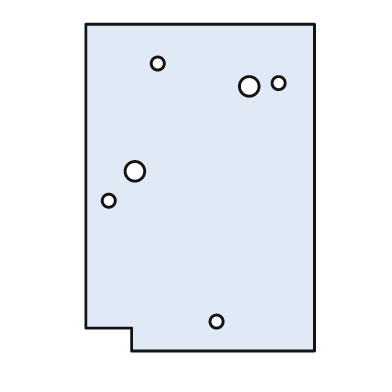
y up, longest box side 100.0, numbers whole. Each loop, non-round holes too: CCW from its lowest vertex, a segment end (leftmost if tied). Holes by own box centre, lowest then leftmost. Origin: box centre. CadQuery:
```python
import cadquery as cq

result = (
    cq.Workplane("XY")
    .moveTo(-21.0, -50.0)
    .lineTo(35.0, -50.0)
    .lineTo(35.0, 50.0)
    .lineTo(-35.0, 50.0)
    .lineTo(-35.0, -43.0)
    .lineTo(-21.0, -43.0)
    .close()
    .moveTo(5.0, -41.0)
    .circle(2.0)
    .moveTo(-28.0, -4.0)
    .circle(2.0)
    .moveTo(-20.0, 5.0)
    .circle(3.0)
    .moveTo(15.0, 31.0)
    .circle(3.0)
    .moveTo(24.0, 32.0)
    .circle(2.0)
    .moveTo(-13.0, 38.0)
    .circle(2.0)
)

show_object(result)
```